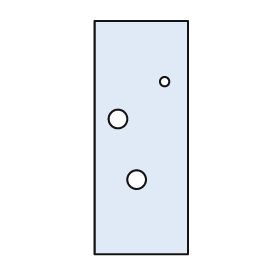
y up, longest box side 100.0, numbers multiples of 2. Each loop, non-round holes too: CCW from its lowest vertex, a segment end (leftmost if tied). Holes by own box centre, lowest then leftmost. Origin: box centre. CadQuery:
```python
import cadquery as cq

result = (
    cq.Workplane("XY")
    .moveTo(-20.0, -50.0)
    .lineTo(20.0, -50.0)
    .lineTo(20.0, 50.0)
    .lineTo(-20.0, 50.0)
    .close()
    .moveTo(-2.0, -18.0)
    .circle(4.0)
    .moveTo(-10.0, 8.0)
    .circle(4.0)
    .moveTo(10.0, 24.0)
    .circle(2.0)
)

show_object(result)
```